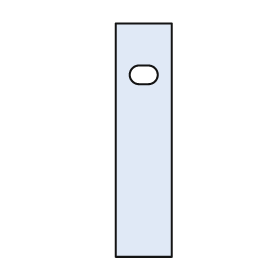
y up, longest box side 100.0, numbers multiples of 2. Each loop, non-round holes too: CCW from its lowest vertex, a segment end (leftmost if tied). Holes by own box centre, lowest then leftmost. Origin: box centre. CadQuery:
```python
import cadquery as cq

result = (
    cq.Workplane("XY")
    .moveTo(-12.0, -50.0)
    .lineTo(12.0, -50.0)
    .lineTo(12.0, 50.0)
    .lineTo(-12.0, 50.0)
    .close()
    .moveTo(-2.0, 24.0)
    .lineTo(2.0, 24.0)
    .threePointArc((6.0, 28.0), (2.0, 32.0))
    .lineTo(-2.0, 32.0)
    .threePointArc((-6.0, 28.0), (-2.0, 24.0))
    .close()
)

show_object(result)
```